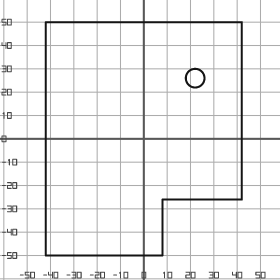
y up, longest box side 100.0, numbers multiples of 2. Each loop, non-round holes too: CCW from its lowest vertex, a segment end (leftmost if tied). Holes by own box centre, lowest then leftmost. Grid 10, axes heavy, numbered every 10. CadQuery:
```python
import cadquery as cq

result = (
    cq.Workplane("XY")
    .moveTo(-42.0, -50.0)
    .lineTo(8.0, -50.0)
    .lineTo(8.0, -26.0)
    .lineTo(42.0, -26.0)
    .lineTo(42.0, 50.0)
    .lineTo(-42.0, 50.0)
    .close()
    .moveTo(22.0, 26.0)
    .circle(4.0)
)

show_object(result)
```